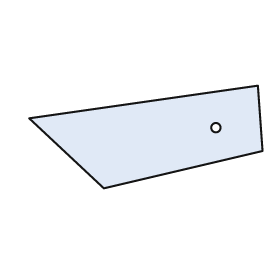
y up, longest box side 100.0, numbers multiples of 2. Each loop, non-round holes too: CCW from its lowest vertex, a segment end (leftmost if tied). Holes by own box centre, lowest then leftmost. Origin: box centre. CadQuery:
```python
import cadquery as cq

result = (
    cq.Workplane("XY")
    .moveTo(-18.0, -22.0)
    .lineTo(50.0, -6.0)
    .lineTo(48.0, 22.0)
    .lineTo(-50.0, 8.0)
    .close()
    .moveTo(30.0, 4.0)
    .circle(2.0)
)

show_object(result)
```